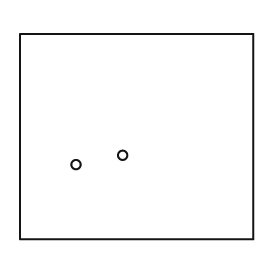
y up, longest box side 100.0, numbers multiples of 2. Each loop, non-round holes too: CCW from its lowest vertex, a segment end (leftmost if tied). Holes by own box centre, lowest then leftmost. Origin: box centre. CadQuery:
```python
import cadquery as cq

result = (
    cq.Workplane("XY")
    .moveTo(-50.0, -44.0)
    .lineTo(50.0, -44.0)
    .lineTo(50.0, 44.0)
    .lineTo(-50.0, 44.0)
    .close()
    .moveTo(-26.0, -12.0)
    .circle(2.0)
    .moveTo(-6.0, -8.0)
    .circle(2.0)
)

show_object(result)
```